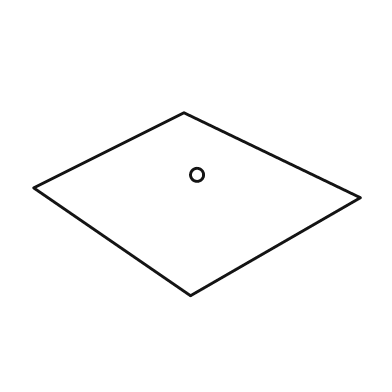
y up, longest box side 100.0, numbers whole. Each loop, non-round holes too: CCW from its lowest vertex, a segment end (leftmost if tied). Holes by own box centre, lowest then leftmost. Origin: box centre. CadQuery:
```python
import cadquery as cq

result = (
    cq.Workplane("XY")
    .moveTo(-2.0, -28.0)
    .lineTo(50.0, 2.0)
    .lineTo(-4.0, 28.0)
    .lineTo(-50.0, 5.0)
    .close()
    .moveTo(0.0, 9.0)
    .circle(2.0)
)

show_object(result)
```